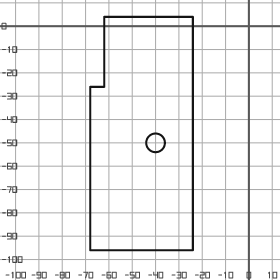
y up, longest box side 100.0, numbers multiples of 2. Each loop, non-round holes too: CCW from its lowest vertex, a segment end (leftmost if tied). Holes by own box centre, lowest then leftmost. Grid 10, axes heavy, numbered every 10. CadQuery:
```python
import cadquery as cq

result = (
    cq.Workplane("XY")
    .moveTo(-68.0, -96.0)
    .lineTo(-24.0, -96.0)
    .lineTo(-24.0, 4.0)
    .lineTo(-62.0, 4.0)
    .lineTo(-62.0, -26.0)
    .lineTo(-68.0, -26.0)
    .close()
    .moveTo(-40.0, -50.0)
    .circle(4.0)
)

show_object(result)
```